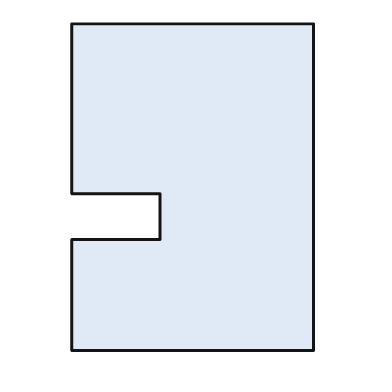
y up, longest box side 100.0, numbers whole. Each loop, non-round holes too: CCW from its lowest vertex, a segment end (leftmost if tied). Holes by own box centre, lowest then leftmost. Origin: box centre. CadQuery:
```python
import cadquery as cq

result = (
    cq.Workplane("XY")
    .moveTo(-37.0, -50.0)
    .lineTo(37.0, -50.0)
    .lineTo(37.0, 50.0)
    .lineTo(-37.0, 50.0)
    .lineTo(-37.0, -2.0)
    .lineTo(-10.0, -2.0)
    .lineTo(-10.0, -16.0)
    .lineTo(-37.0, -16.0)
    .close()
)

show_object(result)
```